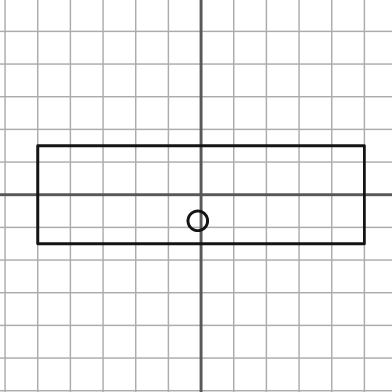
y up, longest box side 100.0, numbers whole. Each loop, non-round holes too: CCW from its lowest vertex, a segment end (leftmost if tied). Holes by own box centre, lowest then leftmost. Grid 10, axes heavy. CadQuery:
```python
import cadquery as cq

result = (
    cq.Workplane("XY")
    .moveTo(-50.0, -15.0)
    .lineTo(50.0, -15.0)
    .lineTo(50.0, 15.0)
    .lineTo(-50.0, 15.0)
    .close()
    .moveTo(-1.0, -8.0)
    .circle(3.0)
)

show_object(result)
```